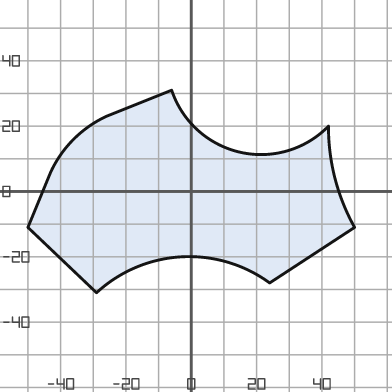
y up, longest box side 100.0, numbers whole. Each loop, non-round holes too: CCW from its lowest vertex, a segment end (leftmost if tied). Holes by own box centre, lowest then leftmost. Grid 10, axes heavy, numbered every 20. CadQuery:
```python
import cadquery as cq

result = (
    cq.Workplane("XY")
    .moveTo(-29.0, -31.0)
    .threePointArc((-3.0, -20.0), (24.0, -28.0))
    .lineTo(50.0, -11.0)
    .threePointArc((44.0, 4.0), (42.0, 20.0))
    .threePointArc((15.0, 12.0), (-6.0, 31.0))
    .lineTo(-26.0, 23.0)
    .threePointArc((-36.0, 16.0), (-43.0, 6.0))
    .lineTo(-50.0, -11.0)
    .close()
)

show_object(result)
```